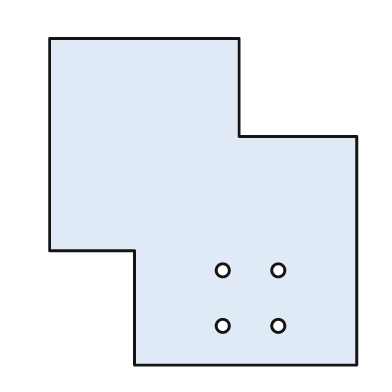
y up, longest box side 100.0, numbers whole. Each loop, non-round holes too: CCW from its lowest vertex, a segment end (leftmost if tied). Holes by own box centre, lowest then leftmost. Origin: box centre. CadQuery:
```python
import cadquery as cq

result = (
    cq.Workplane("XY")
    .moveTo(-21.0, -50.0)
    .lineTo(47.0, -50.0)
    .lineTo(47.0, 20.0)
    .lineTo(11.0, 20.0)
    .lineTo(11.0, 50.0)
    .lineTo(-47.0, 50.0)
    .lineTo(-47.0, -15.0)
    .lineTo(-21.0, -15.0)
    .close()
    .moveTo(6.0, -38.0)
    .circle(2.0)
    .moveTo(23.0, -38.0)
    .circle(2.0)
    .moveTo(6.0, -21.0)
    .circle(2.0)
    .moveTo(23.0, -21.0)
    .circle(2.0)
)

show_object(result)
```